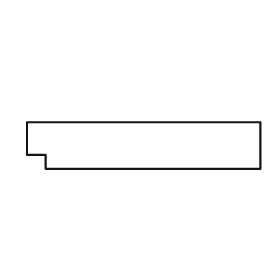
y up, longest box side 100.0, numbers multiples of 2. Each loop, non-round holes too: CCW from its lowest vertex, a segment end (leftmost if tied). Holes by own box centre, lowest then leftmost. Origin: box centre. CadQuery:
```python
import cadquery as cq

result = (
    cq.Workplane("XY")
    .moveTo(-42.0, -10.0)
    .lineTo(50.0, -10.0)
    .lineTo(50.0, 10.0)
    .lineTo(-50.0, 10.0)
    .lineTo(-50.0, -4.0)
    .lineTo(-42.0, -4.0)
    .close()
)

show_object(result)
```